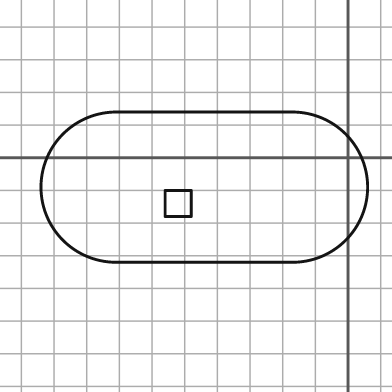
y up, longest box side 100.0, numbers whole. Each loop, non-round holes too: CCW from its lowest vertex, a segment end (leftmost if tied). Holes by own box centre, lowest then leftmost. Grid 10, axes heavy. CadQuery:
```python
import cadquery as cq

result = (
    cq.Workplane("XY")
    .moveTo(-71.0, -32.0)
    .lineTo(-17.0, -32.0)
    .threePointArc((6.0, -9.0), (-17.0, 14.0))
    .lineTo(-71.0, 14.0)
    .threePointArc((-94.0, -9.0), (-71.0, -32.0))
    .close()
    .moveTo(-56.0, -18.0)
    .lineTo(-48.0, -18.0)
    .lineTo(-48.0, -10.0)
    .lineTo(-56.0, -10.0)
    .close()
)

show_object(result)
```